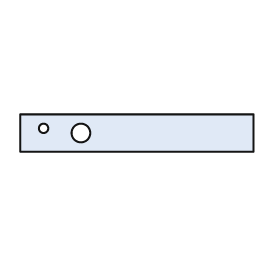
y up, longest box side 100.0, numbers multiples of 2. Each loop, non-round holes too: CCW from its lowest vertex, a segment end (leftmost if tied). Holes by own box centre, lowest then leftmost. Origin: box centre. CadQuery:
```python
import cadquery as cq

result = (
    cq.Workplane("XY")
    .moveTo(-50.0, -8.0)
    .lineTo(50.0, -8.0)
    .lineTo(50.0, 8.0)
    .lineTo(-50.0, 8.0)
    .close()
    .moveTo(-24.0, 0.0)
    .circle(4.0)
    .moveTo(-40.0, 2.0)
    .circle(2.0)
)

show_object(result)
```